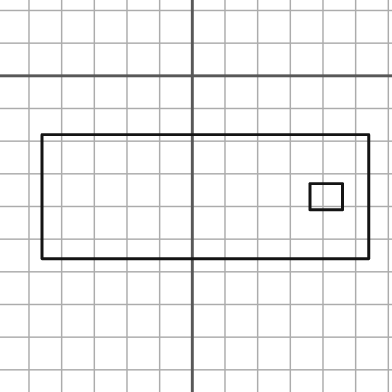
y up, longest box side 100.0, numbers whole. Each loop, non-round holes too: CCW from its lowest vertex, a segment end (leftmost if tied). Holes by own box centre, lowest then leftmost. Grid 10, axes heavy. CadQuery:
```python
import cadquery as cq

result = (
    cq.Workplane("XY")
    .moveTo(-46.0, -56.0)
    .lineTo(54.0, -56.0)
    .lineTo(54.0, -18.0)
    .lineTo(-46.0, -18.0)
    .close()
    .moveTo(36.0, -41.0)
    .lineTo(46.0, -41.0)
    .lineTo(46.0, -33.0)
    .lineTo(36.0, -33.0)
    .close()
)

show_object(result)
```